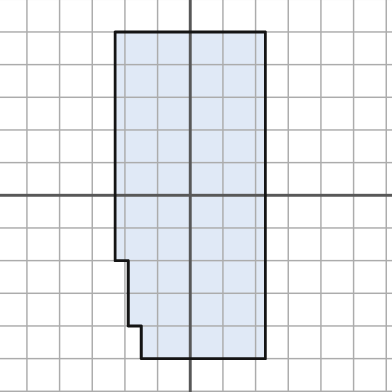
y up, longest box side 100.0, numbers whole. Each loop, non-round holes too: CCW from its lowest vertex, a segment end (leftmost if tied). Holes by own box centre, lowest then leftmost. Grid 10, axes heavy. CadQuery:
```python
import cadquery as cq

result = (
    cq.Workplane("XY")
    .moveTo(-15.0, -50.0)
    .lineTo(23.0, -50.0)
    .lineTo(23.0, 50.0)
    .lineTo(-23.0, 50.0)
    .lineTo(-23.0, -20.0)
    .lineTo(-19.0, -20.0)
    .lineTo(-19.0, -40.0)
    .lineTo(-15.0, -40.0)
    .close()
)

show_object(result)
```